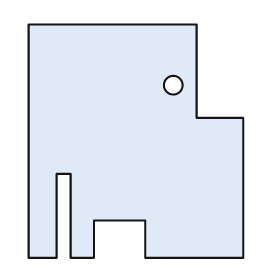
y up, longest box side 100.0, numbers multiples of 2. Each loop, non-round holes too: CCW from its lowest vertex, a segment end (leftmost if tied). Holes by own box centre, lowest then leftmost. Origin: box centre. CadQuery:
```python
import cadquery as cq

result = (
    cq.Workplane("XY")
    .moveTo(-46.0, -50.0)
    .lineTo(-34.0, -50.0)
    .lineTo(-34.0, -14.0)
    .lineTo(-28.0, -14.0)
    .lineTo(-28.0, -50.0)
    .lineTo(-18.0, -50.0)
    .lineTo(-18.0, -34.0)
    .lineTo(4.0, -34.0)
    .lineTo(4.0, -50.0)
    .lineTo(46.0, -50.0)
    .lineTo(46.0, 10.0)
    .lineTo(26.0, 10.0)
    .lineTo(26.0, 50.0)
    .lineTo(-46.0, 50.0)
    .close()
    .moveTo(16.0, 24.0)
    .circle(4.0)
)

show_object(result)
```